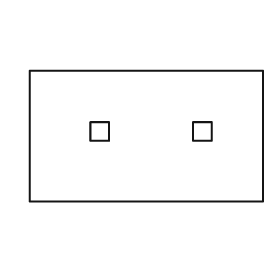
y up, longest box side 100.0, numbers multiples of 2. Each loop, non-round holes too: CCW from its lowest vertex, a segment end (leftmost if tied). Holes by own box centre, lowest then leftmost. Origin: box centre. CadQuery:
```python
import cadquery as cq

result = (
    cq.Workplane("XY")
    .moveTo(-50.0, -28.0)
    .lineTo(50.0, -28.0)
    .lineTo(50.0, 28.0)
    .lineTo(-50.0, 28.0)
    .close()
    .moveTo(-24.0, -2.0)
    .lineTo(-16.0, -2.0)
    .lineTo(-16.0, 6.0)
    .lineTo(-24.0, 6.0)
    .close()
    .moveTo(20.0, -2.0)
    .lineTo(28.0, -2.0)
    .lineTo(28.0, 6.0)
    .lineTo(20.0, 6.0)
    .close()
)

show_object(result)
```